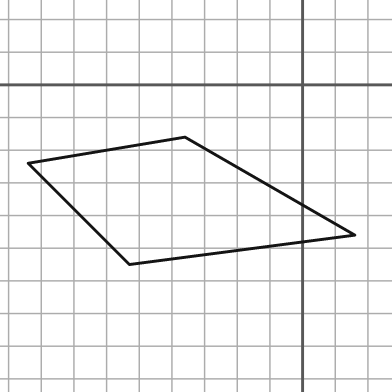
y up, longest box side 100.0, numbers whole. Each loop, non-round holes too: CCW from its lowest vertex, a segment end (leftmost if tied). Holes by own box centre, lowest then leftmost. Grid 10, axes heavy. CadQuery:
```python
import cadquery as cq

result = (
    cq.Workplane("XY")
    .moveTo(-53.0, -55.0)
    .lineTo(16.0, -46.0)
    .lineTo(-36.0, -16.0)
    .lineTo(-84.0, -24.0)
    .close()
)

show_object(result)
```